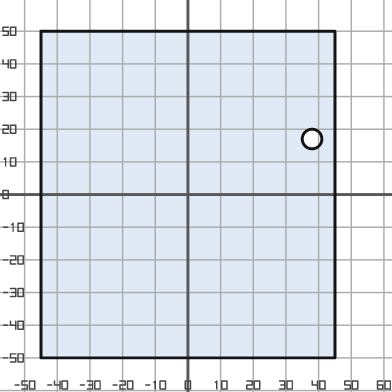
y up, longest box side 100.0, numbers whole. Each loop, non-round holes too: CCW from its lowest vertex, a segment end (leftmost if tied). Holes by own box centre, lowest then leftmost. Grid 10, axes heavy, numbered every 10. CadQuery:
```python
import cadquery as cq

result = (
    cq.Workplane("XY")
    .moveTo(-45.0, -50.0)
    .lineTo(45.0, -50.0)
    .lineTo(45.0, 50.0)
    .lineTo(-45.0, 50.0)
    .close()
    .moveTo(38.0, 17.0)
    .circle(3.0)
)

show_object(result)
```